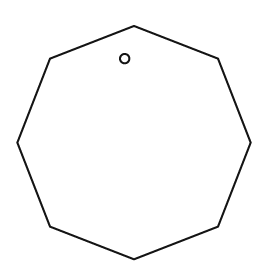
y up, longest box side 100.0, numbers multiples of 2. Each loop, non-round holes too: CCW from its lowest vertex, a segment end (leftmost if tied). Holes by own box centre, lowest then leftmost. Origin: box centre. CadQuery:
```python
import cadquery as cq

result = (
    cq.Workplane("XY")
    .moveTo(0.0, -50.0)
    .lineTo(36.0, -36.0)
    .lineTo(50.0, 0.0)
    .lineTo(36.0, 36.0)
    .lineTo(0.0, 50.0)
    .lineTo(-36.0, 36.0)
    .lineTo(-50.0, 0.0)
    .lineTo(-36.0, -36.0)
    .close()
    .moveTo(-4.0, 36.0)
    .circle(2.0)
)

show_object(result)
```